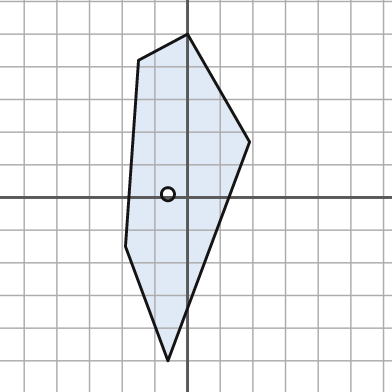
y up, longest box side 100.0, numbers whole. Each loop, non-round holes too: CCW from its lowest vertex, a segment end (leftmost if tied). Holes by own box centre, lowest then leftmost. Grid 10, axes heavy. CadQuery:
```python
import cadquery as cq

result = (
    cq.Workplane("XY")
    .moveTo(-6.0, -50.0)
    .lineTo(19.0, 17.0)
    .lineTo(0.0, 50.0)
    .lineTo(-15.0, 42.0)
    .lineTo(-19.0, -15.0)
    .close()
    .moveTo(-6.0, 1.0)
    .circle(2.0)
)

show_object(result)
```